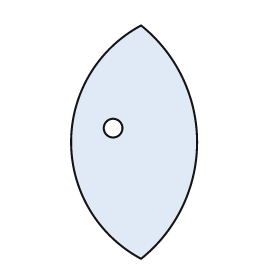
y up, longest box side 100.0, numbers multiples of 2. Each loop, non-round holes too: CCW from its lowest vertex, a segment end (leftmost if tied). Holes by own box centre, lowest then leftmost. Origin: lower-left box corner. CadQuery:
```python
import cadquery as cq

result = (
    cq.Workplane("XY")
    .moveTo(30.0, 0.0)
    .threePointArc((54.0, 50.0), (30.0, 100.0))
    .threePointArc((0.0, 50.0), (30.0, 0.0))
    .close()
    .moveTo(18.0, 56.0)
    .circle(4.0)
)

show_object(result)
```